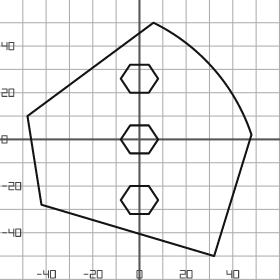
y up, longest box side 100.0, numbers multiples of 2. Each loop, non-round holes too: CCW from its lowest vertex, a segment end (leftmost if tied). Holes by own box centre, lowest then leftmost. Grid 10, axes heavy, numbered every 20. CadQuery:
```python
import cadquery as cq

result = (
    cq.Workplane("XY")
    .moveTo(32.0, -50.0)
    .lineTo(48.0, 2.0)
    .threePointArc((32.0, 30.0), (6.0, 50.0))
    .lineTo(-48.0, 10.0)
    .lineTo(-42.0, -28.0)
    .close()
    .moveTo(-4.0, -32.0)
    .lineTo(4.0, -32.0)
    .lineTo(8.0, -26.0)
    .lineTo(4.0, -20.0)
    .lineTo(-4.0, -20.0)
    .lineTo(-8.0, -26.0)
    .close()
    .moveTo(-4.0, -6.0)
    .lineTo(4.0, -6.0)
    .lineTo(8.0, 0.0)
    .lineTo(4.0, 6.0)
    .lineTo(-4.0, 6.0)
    .lineTo(-8.0, 0.0)
    .close()
    .moveTo(-4.0, 20.0)
    .lineTo(4.0, 20.0)
    .lineTo(8.0, 26.0)
    .lineTo(4.0, 32.0)
    .lineTo(-4.0, 32.0)
    .lineTo(-8.0, 26.0)
    .close()
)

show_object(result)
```